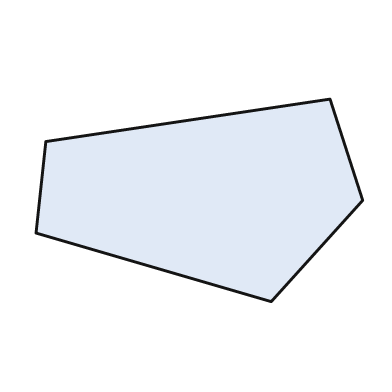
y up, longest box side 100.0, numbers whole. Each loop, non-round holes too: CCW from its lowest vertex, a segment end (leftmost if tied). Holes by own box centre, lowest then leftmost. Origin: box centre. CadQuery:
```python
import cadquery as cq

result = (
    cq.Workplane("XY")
    .moveTo(22.0, -31.0)
    .lineTo(50.0, 0.0)
    .lineTo(40.0, 31.0)
    .lineTo(-47.0, 18.0)
    .lineTo(-50.0, -10.0)
    .close()
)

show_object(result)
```